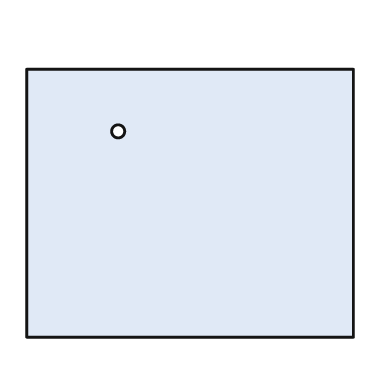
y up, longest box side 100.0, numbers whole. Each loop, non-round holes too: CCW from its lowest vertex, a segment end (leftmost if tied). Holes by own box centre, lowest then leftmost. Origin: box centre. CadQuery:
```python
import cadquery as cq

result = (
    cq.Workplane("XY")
    .moveTo(-50.0, -41.0)
    .lineTo(50.0, -41.0)
    .lineTo(50.0, 41.0)
    .lineTo(-50.0, 41.0)
    .close()
    .moveTo(-22.0, 22.0)
    .circle(2.0)
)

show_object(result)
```